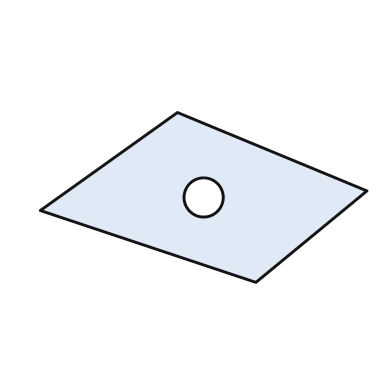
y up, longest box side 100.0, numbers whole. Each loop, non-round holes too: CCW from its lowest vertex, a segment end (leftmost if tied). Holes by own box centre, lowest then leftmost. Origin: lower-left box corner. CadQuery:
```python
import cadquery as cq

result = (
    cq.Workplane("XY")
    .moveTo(66.0, 0.0)
    .lineTo(100.0, 28.0)
    .lineTo(42.0, 52.0)
    .lineTo(0.0, 22.0)
    .close()
    .moveTo(50.0, 26.0)
    .circle(6.0)
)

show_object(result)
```